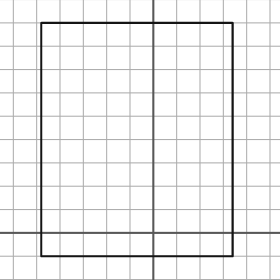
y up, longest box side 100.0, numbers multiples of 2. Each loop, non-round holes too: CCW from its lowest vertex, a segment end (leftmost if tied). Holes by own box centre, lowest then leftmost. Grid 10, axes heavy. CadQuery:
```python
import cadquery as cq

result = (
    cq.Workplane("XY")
    .moveTo(-48.0, -10.0)
    .lineTo(34.0, -10.0)
    .lineTo(34.0, 90.0)
    .lineTo(-48.0, 90.0)
    .close()
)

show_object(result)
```